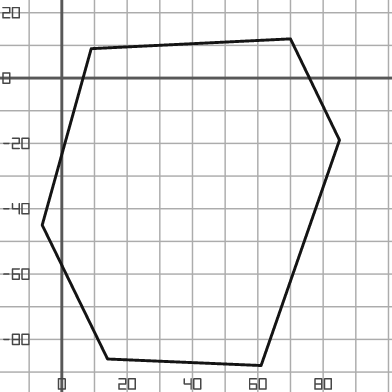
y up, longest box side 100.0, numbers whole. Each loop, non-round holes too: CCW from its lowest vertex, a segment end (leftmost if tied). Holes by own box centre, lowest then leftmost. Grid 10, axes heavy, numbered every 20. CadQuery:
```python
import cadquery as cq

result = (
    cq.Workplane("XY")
    .moveTo(61.0, -88.0)
    .lineTo(85.0, -19.0)
    .lineTo(70.0, 12.0)
    .lineTo(9.0, 9.0)
    .lineTo(-6.0, -45.0)
    .lineTo(14.0, -86.0)
    .close()
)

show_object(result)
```